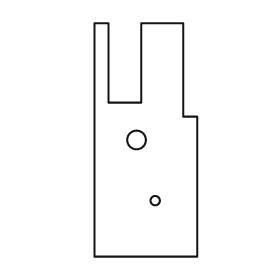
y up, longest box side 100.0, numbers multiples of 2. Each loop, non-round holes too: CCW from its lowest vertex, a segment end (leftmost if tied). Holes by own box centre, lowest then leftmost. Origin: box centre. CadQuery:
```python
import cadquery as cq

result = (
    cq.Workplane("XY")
    .moveTo(-22.0, -50.0)
    .lineTo(22.0, -50.0)
    .lineTo(22.0, 10.0)
    .lineTo(16.0, 10.0)
    .lineTo(16.0, 50.0)
    .lineTo(-2.0, 50.0)
    .lineTo(-2.0, 16.0)
    .lineTo(-16.0, 16.0)
    .lineTo(-16.0, 50.0)
    .lineTo(-22.0, 50.0)
    .close()
    .moveTo(4.0, -26.0)
    .circle(2.0)
    .moveTo(-4.0, 0.0)
    .circle(4.0)
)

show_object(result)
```